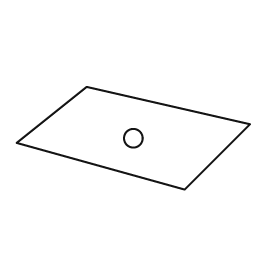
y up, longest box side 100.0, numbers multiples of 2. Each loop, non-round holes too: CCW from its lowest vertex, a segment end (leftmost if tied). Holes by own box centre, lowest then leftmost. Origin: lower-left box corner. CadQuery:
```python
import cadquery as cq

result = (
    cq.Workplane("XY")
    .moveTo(72.0, 0.0)
    .lineTo(100.0, 28.0)
    .lineTo(30.0, 44.0)
    .lineTo(0.0, 20.0)
    .close()
    .moveTo(50.0, 22.0)
    .circle(4.0)
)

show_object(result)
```